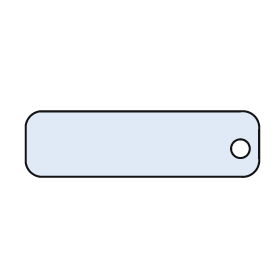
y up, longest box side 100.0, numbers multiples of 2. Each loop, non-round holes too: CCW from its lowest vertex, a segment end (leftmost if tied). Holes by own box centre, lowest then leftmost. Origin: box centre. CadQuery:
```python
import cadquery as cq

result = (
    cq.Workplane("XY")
    .moveTo(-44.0, -14.0)
    .lineTo(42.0, -14.0)
    .threePointArc((48.0, -12.0), (50.0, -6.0))
    .lineTo(50.0, 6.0)
    .threePointArc((48.0, 12.0), (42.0, 14.0))
    .lineTo(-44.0, 14.0)
    .threePointArc((-48.0, 12.0), (-50.0, 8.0))
    .lineTo(-50.0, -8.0)
    .threePointArc((-48.0, -12.0), (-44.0, -14.0))
    .close()
    .moveTo(42.0, -2.0)
    .circle(4.0)
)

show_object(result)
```